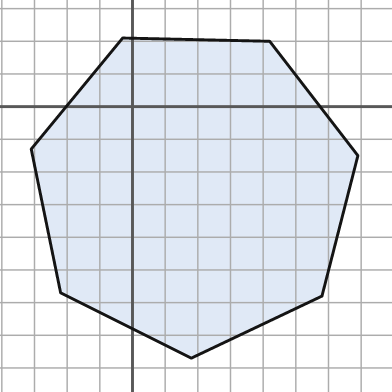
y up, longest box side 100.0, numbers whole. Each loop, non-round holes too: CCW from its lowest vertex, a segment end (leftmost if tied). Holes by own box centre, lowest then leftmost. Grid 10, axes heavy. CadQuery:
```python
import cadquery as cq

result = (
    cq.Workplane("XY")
    .moveTo(18.0, -77.0)
    .lineTo(58.0, -58.0)
    .lineTo(69.0, -15.0)
    .lineTo(42.0, 20.0)
    .lineTo(-3.0, 21.0)
    .lineTo(-31.0, -13.0)
    .lineTo(-22.0, -57.0)
    .close()
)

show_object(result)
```